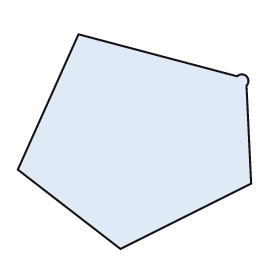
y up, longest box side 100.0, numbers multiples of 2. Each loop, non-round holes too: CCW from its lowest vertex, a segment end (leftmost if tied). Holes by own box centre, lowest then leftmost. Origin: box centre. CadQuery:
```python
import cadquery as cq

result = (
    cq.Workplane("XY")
    .moveTo(-6.0, -46.0)
    .lineTo(50.0, -18.0)
    .lineTo(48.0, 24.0)
    .threePointArc((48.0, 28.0), (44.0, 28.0))
    .lineTo(-24.0, 46.0)
    .lineTo(-50.0, -12.0)
    .close()
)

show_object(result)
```